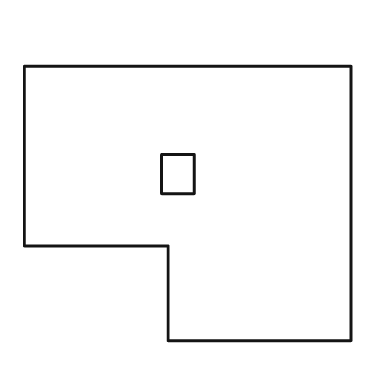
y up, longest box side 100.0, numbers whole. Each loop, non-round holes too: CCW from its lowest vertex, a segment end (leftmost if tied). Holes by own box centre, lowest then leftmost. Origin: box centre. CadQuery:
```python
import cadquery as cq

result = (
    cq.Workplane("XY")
    .moveTo(-6.0, -42.0)
    .lineTo(50.0, -42.0)
    .lineTo(50.0, 42.0)
    .lineTo(-50.0, 42.0)
    .lineTo(-50.0, -13.0)
    .lineTo(-6.0, -13.0)
    .close()
    .moveTo(-8.0, 3.0)
    .lineTo(2.0, 3.0)
    .lineTo(2.0, 15.0)
    .lineTo(-8.0, 15.0)
    .close()
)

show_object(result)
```